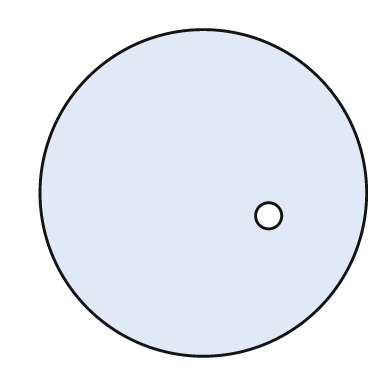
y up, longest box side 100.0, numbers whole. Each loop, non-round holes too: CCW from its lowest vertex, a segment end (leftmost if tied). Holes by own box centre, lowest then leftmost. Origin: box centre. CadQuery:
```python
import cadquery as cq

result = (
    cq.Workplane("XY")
    .moveTo(0.0, 0.0)
    .circle(50.0)
    .moveTo(20.0, -7.0)
    .circle(4.0)
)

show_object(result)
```